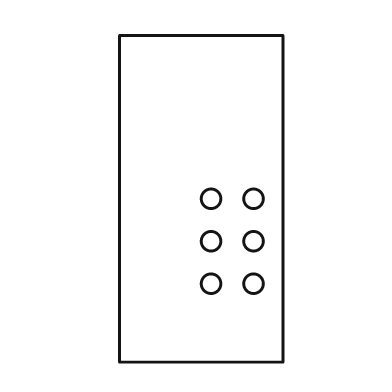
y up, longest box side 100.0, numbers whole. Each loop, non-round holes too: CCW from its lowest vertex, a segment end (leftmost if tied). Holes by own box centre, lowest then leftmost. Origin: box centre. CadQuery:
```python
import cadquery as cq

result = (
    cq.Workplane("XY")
    .moveTo(-25.0, -50.0)
    .lineTo(25.0, -50.0)
    .lineTo(25.0, 50.0)
    .lineTo(-25.0, 50.0)
    .close()
    .moveTo(3.0, -26.0)
    .circle(3.0)
    .moveTo(16.0, -26.0)
    .circle(3.0)
    .moveTo(3.0, -13.0)
    .circle(3.0)
    .moveTo(16.0, -13.0)
    .circle(3.0)
    .moveTo(3.0, 0.0)
    .circle(3.0)
    .moveTo(16.0, 0.0)
    .circle(3.0)
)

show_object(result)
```